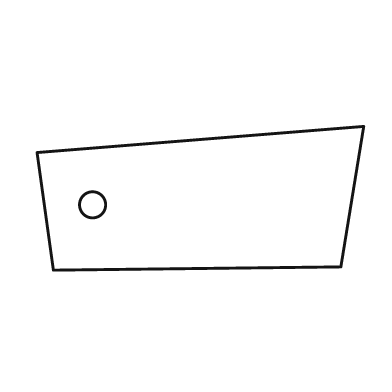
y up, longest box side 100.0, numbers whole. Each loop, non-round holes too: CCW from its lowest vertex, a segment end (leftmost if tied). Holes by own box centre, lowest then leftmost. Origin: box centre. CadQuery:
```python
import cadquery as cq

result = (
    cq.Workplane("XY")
    .moveTo(-45.0, -22.0)
    .lineTo(43.0, -21.0)
    .lineTo(50.0, 22.0)
    .lineTo(-50.0, 14.0)
    .close()
    .moveTo(-33.0, -2.0)
    .circle(4.0)
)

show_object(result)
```